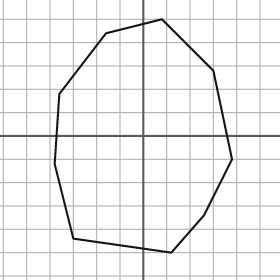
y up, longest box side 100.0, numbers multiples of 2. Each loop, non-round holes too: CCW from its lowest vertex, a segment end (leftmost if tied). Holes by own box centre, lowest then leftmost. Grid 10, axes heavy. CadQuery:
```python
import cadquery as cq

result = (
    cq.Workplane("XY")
    .moveTo(12.0, -50.0)
    .lineTo(26.0, -34.0)
    .lineTo(38.0, -10.0)
    .lineTo(30.0, 28.0)
    .lineTo(8.0, 50.0)
    .lineTo(-16.0, 44.0)
    .lineTo(-36.0, 18.0)
    .lineTo(-38.0, -12.0)
    .lineTo(-30.0, -44.0)
    .close()
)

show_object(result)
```